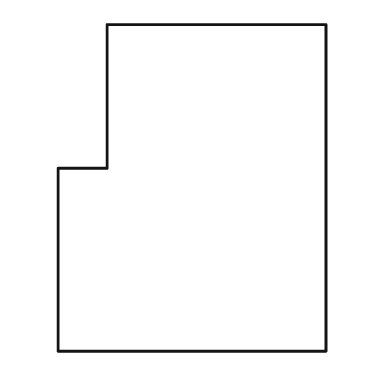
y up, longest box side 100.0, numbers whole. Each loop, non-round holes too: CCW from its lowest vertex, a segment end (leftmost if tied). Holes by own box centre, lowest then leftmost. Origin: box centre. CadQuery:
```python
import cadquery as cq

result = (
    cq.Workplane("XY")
    .moveTo(-41.0, -50.0)
    .lineTo(41.0, -50.0)
    .lineTo(41.0, 50.0)
    .lineTo(-26.0, 50.0)
    .lineTo(-26.0, 6.0)
    .lineTo(-41.0, 6.0)
    .close()
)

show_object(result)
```